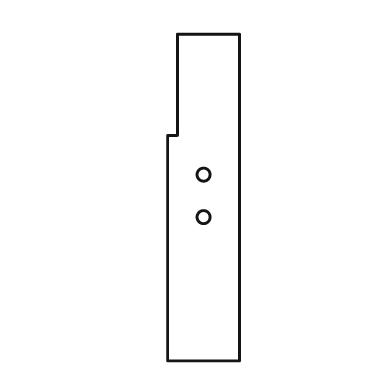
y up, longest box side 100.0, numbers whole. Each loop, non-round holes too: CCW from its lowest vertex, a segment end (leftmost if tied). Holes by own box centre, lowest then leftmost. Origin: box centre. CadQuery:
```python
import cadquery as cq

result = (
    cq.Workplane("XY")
    .moveTo(-11.0, -50.0)
    .lineTo(11.0, -50.0)
    .lineTo(11.0, 50.0)
    .lineTo(-8.0, 50.0)
    .lineTo(-8.0, 19.0)
    .lineTo(-11.0, 19.0)
    .close()
    .moveTo(0.0, -6.0)
    .circle(2.0)
    .moveTo(0.0, 7.0)
    .circle(2.0)
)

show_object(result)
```